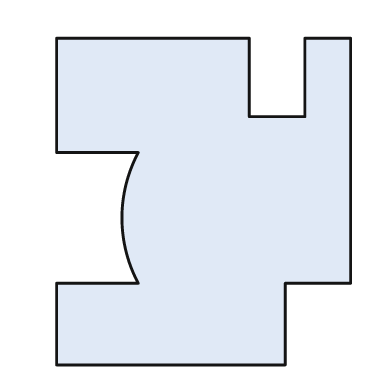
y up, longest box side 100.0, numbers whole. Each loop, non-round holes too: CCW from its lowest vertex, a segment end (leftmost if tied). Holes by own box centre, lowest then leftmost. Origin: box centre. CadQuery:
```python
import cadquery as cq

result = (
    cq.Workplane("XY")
    .moveTo(-45.0, -50.0)
    .lineTo(25.0, -50.0)
    .lineTo(25.0, -25.0)
    .lineTo(45.0, -25.0)
    .lineTo(45.0, 50.0)
    .lineTo(31.0, 50.0)
    .lineTo(31.0, 26.0)
    .lineTo(14.0, 26.0)
    .lineTo(14.0, 50.0)
    .lineTo(-45.0, 50.0)
    .lineTo(-45.0, 15.0)
    .lineTo(-20.0, 15.0)
    .threePointArc((-25.0, -5.0), (-20.0, -25.0))
    .lineTo(-45.0, -25.0)
    .close()
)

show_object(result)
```